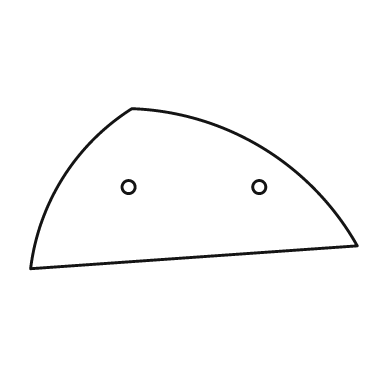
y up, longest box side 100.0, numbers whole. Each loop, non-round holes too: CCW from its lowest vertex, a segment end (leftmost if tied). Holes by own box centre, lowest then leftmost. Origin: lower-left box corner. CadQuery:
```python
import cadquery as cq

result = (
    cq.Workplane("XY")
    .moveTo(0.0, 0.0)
    .lineTo(100.0, 7.0)
    .threePointArc((71.0, 37.0), (31.0, 49.0))
    .threePointArc((10.0, 28.0), (0.0, 0.0))
    .close()
    .moveTo(30.0, 25.0)
    .circle(2.0)
    .moveTo(70.0, 25.0)
    .circle(2.0)
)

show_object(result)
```